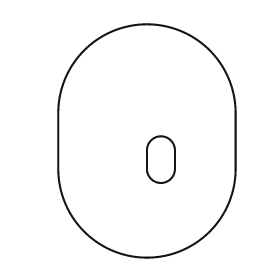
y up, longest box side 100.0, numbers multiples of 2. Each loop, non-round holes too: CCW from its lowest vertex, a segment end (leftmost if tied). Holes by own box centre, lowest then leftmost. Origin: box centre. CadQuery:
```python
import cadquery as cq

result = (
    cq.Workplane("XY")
    .moveTo(-38.0, -12.0)
    .threePointArc((0.0, -50.0), (38.0, -12.0))
    .lineTo(38.0, 12.0)
    .threePointArc((0.0, 50.0), (-38.0, 12.0))
    .close()
    .moveTo(0.0, -12.0)
    .threePointArc((6.0, -18.0), (12.0, -12.0))
    .lineTo(12.0, -4.0)
    .threePointArc((6.0, 2.0), (0.0, -4.0))
    .close()
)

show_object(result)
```